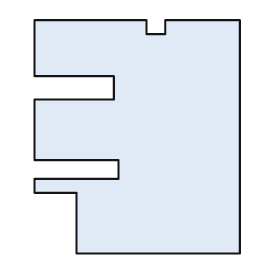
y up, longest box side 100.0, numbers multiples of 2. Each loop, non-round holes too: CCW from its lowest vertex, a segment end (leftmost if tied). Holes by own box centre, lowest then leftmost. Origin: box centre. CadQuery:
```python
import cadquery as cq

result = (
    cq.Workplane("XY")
    .moveTo(-26.0, -50.0)
    .lineTo(44.0, -50.0)
    .lineTo(44.0, 50.0)
    .lineTo(12.0, 50.0)
    .lineTo(12.0, 44.0)
    .lineTo(4.0, 44.0)
    .lineTo(4.0, 50.0)
    .lineTo(-44.0, 50.0)
    .lineTo(-44.0, 26.0)
    .lineTo(-10.0, 26.0)
    .lineTo(-10.0, 16.0)
    .lineTo(-44.0, 16.0)
    .lineTo(-44.0, -10.0)
    .lineTo(-8.0, -10.0)
    .lineTo(-8.0, -18.0)
    .lineTo(-44.0, -18.0)
    .lineTo(-44.0, -24.0)
    .lineTo(-26.0, -24.0)
    .close()
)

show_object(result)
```